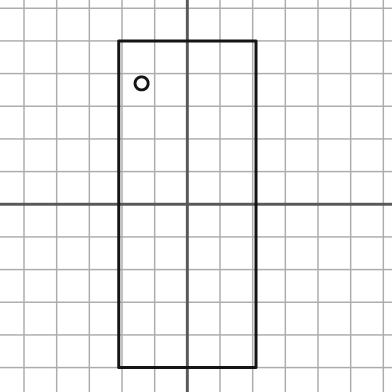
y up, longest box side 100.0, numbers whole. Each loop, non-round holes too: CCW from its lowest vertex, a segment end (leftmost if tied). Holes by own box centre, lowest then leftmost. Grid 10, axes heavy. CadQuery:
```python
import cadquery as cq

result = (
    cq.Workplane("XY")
    .moveTo(-21.0, -50.0)
    .lineTo(21.0, -50.0)
    .lineTo(21.0, 50.0)
    .lineTo(-21.0, 50.0)
    .close()
    .moveTo(-14.0, 37.0)
    .circle(2.0)
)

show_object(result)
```